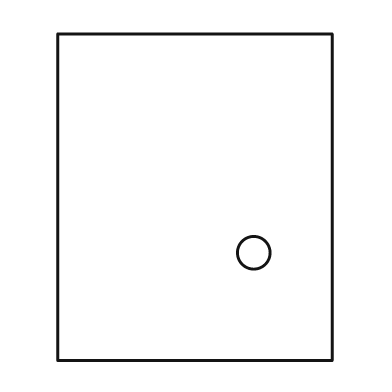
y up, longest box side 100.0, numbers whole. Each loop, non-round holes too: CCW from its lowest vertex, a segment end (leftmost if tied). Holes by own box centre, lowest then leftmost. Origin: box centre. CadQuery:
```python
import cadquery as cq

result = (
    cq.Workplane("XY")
    .moveTo(-42.0, -50.0)
    .lineTo(42.0, -50.0)
    .lineTo(42.0, 50.0)
    .lineTo(-42.0, 50.0)
    .close()
    .moveTo(18.0, -17.0)
    .circle(5.0)
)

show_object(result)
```